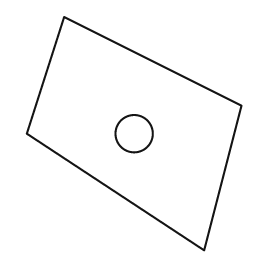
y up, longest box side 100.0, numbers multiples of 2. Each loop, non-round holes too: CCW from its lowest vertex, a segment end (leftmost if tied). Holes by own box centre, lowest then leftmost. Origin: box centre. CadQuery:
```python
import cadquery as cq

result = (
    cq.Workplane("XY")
    .moveTo(30.0, -50.0)
    .lineTo(46.0, 12.0)
    .lineTo(-30.0, 50.0)
    .lineTo(-46.0, 0.0)
    .close()
    .moveTo(0.0, 0.0)
    .circle(8.0)
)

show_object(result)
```